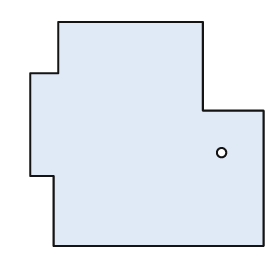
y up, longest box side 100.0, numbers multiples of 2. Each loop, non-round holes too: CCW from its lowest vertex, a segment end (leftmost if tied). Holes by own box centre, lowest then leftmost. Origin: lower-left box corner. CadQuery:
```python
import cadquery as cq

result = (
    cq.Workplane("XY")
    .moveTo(10.0, 0.0)
    .lineTo(100.0, 0.0)
    .lineTo(100.0, 58.0)
    .lineTo(74.0, 58.0)
    .lineTo(74.0, 96.0)
    .lineTo(12.0, 96.0)
    .lineTo(12.0, 74.0)
    .lineTo(0.0, 74.0)
    .lineTo(0.0, 30.0)
    .lineTo(10.0, 30.0)
    .close()
    .moveTo(82.0, 40.0)
    .circle(2.0)
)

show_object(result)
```